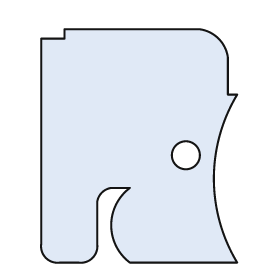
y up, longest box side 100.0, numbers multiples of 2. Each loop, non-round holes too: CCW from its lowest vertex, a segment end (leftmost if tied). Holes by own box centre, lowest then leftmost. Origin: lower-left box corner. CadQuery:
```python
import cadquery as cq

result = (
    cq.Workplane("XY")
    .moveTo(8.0, 0.0)
    .lineTo(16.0, 0.0)
    .threePointArc((22.0, 2.0), (24.0, 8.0))
    .lineTo(24.0, 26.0)
    .threePointArc((26.0, 30.0), (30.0, 32.0))
    .lineTo(38.0, 32.0)
    .threePointArc((30.0, 16.0), (38.0, 0.0))
    .lineTo(84.0, 0.0)
    .threePointArc((74.0, 36.0), (84.0, 72.0))
    .lineTo(80.0, 72.0)
    .lineTo(80.0, 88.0)
    .threePointArc((76.0, 96.0), (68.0, 100.0))
    .lineTo(10.0, 100.0)
    .lineTo(10.0, 96.0)
    .lineTo(0.0, 96.0)
    .lineTo(0.0, 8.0)
    .threePointArc((2.0, 2.0), (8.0, 0.0))
    .close()
    .moveTo(62.0, 46.0)
    .circle(6.0)
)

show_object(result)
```